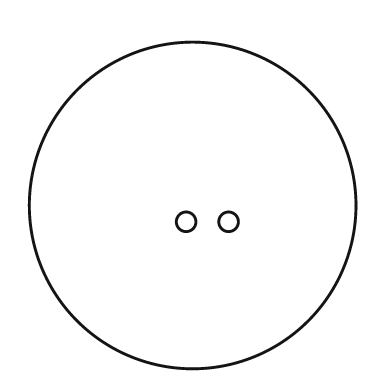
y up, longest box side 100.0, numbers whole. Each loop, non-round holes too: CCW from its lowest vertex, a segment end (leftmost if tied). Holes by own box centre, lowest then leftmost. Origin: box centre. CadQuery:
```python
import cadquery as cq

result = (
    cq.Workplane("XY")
    .moveTo(0.0, 0.0)
    .circle(50.0)
    .moveTo(-2.0, -5.0)
    .circle(3.0)
    .moveTo(11.0, -5.0)
    .circle(3.0)
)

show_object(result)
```